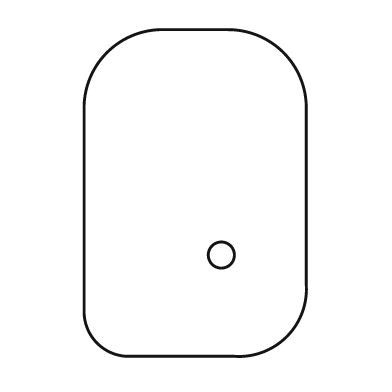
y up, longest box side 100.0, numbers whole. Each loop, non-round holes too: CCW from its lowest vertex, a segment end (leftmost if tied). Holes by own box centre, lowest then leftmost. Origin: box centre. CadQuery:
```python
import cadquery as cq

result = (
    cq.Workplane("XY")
    .moveTo(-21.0, -50.0)
    .lineTo(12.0, -50.0)
    .threePointArc((28.0, -44.0), (34.0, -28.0))
    .lineTo(34.0, 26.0)
    .threePointArc((27.0, 43.0), (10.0, 50.0))
    .lineTo(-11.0, 50.0)
    .threePointArc((-27.0, 43.0), (-34.0, 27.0))
    .lineTo(-34.0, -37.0)
    .threePointArc((-30.0, -46.0), (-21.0, -50.0))
    .close()
    .moveTo(8.0, -19.0)
    .circle(4.0)
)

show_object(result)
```